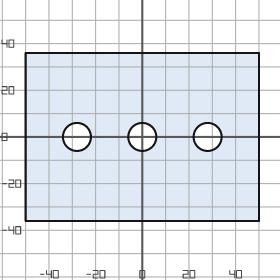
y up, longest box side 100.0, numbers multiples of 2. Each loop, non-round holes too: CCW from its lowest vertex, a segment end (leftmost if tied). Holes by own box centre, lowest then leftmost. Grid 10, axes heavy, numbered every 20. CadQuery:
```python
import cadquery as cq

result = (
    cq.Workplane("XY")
    .moveTo(-50.0, -36.0)
    .lineTo(50.0, -36.0)
    .lineTo(50.0, 36.0)
    .lineTo(-50.0, 36.0)
    .close()
    .moveTo(-28.0, 0.0)
    .circle(6.0)
    .moveTo(0.0, 0.0)
    .circle(6.0)
    .moveTo(28.0, 0.0)
    .circle(6.0)
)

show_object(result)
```